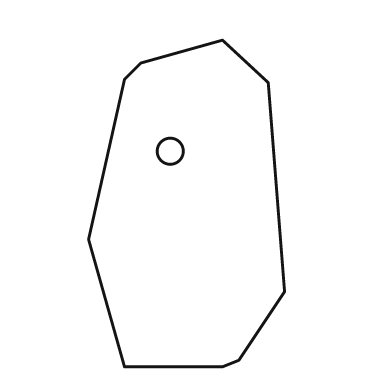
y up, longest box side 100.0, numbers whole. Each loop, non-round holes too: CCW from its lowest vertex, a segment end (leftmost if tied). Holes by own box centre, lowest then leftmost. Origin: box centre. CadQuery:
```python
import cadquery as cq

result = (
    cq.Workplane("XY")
    .moveTo(-19.0, -50.0)
    .lineTo(11.0, -50.0)
    .lineTo(16.0, -48.0)
    .lineTo(30.0, -27.0)
    .lineTo(25.0, 37.0)
    .lineTo(11.0, 50.0)
    .lineTo(-14.0, 43.0)
    .lineTo(-19.0, 38.0)
    .lineTo(-30.0, -11.0)
    .close()
    .moveTo(-5.0, 16.0)
    .circle(4.0)
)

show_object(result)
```